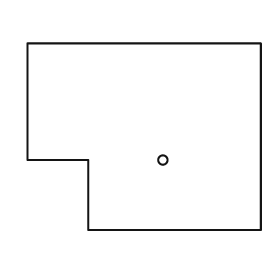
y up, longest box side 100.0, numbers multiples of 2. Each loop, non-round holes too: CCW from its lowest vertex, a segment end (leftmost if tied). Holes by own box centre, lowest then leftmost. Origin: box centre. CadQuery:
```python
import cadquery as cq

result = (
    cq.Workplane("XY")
    .moveTo(-24.0, -40.0)
    .lineTo(50.0, -40.0)
    .lineTo(50.0, 40.0)
    .lineTo(-50.0, 40.0)
    .lineTo(-50.0, -10.0)
    .lineTo(-24.0, -10.0)
    .close()
    .moveTo(8.0, -10.0)
    .circle(2.0)
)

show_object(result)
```